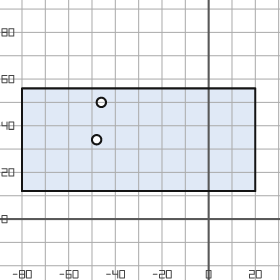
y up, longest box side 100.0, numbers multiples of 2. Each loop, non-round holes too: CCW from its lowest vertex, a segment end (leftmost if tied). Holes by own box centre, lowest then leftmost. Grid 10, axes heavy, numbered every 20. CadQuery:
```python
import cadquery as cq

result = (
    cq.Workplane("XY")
    .moveTo(-80.0, 12.0)
    .lineTo(20.0, 12.0)
    .lineTo(20.0, 56.0)
    .lineTo(-80.0, 56.0)
    .close()
    .moveTo(-48.0, 34.0)
    .circle(2.0)
    .moveTo(-46.0, 50.0)
    .circle(2.0)
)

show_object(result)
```